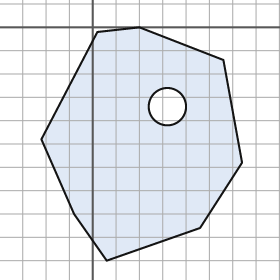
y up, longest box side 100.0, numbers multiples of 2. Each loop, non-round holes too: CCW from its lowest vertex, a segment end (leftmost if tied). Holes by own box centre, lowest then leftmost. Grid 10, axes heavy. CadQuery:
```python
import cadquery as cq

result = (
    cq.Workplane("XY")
    .moveTo(6.0, -100.0)
    .lineTo(46.0, -86.0)
    .lineTo(64.0, -58.0)
    .lineTo(56.0, -14.0)
    .lineTo(20.0, 0.0)
    .lineTo(2.0, -2.0)
    .lineTo(-22.0, -48.0)
    .lineTo(-8.0, -80.0)
    .close()
    .moveTo(32.0, -34.0)
    .circle(8.0)
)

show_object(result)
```